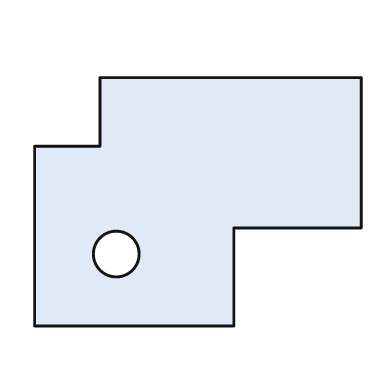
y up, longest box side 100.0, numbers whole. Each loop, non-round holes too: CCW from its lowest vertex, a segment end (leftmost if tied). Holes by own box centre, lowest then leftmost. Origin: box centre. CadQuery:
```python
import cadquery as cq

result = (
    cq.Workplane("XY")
    .moveTo(-50.0, -38.0)
    .lineTo(11.0, -38.0)
    .lineTo(11.0, -8.0)
    .lineTo(50.0, -8.0)
    .lineTo(50.0, 38.0)
    .lineTo(-30.0, 38.0)
    .lineTo(-30.0, 17.0)
    .lineTo(-50.0, 17.0)
    .close()
    .moveTo(-25.0, -16.0)
    .circle(7.0)
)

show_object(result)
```